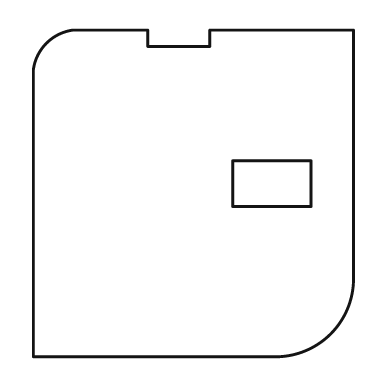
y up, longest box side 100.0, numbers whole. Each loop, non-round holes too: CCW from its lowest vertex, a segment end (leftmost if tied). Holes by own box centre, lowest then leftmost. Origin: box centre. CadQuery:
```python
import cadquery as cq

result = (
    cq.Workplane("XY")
    .moveTo(-49.0, -50.0)
    .lineTo(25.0, -50.0)
    .threePointArc((42.0, -43.0), (49.0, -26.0))
    .lineTo(49.0, 50.0)
    .lineTo(5.0, 50.0)
    .lineTo(5.0, 45.0)
    .lineTo(-14.0, 45.0)
    .lineTo(-14.0, 50.0)
    .lineTo(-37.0, 50.0)
    .threePointArc((-45.0, 46.0), (-49.0, 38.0))
    .close()
    .moveTo(12.0, -4.0)
    .lineTo(36.0, -4.0)
    .lineTo(36.0, 10.0)
    .lineTo(12.0, 10.0)
    .close()
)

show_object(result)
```